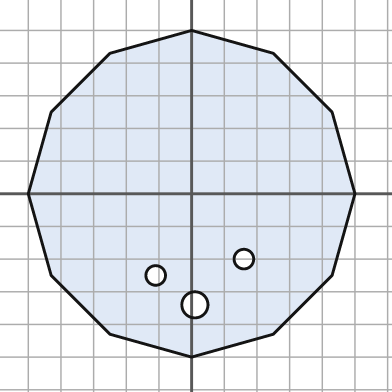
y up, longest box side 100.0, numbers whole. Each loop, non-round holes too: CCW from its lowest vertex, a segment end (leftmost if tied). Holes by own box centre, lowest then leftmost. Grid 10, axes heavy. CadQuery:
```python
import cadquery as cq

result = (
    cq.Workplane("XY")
    .moveTo(0.0, -50.0)
    .lineTo(25.0, -43.0)
    .lineTo(43.0, -25.0)
    .lineTo(50.0, 0.0)
    .lineTo(43.0, 25.0)
    .lineTo(25.0, 43.0)
    .lineTo(0.0, 50.0)
    .lineTo(-25.0, 43.0)
    .lineTo(-43.0, 25.0)
    .lineTo(-50.0, 0.0)
    .lineTo(-43.0, -25.0)
    .lineTo(-25.0, -43.0)
    .close()
    .moveTo(1.0, -34.0)
    .circle(4.0)
    .moveTo(-11.0, -25.0)
    .circle(3.0)
    .moveTo(16.0, -20.0)
    .circle(3.0)
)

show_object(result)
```